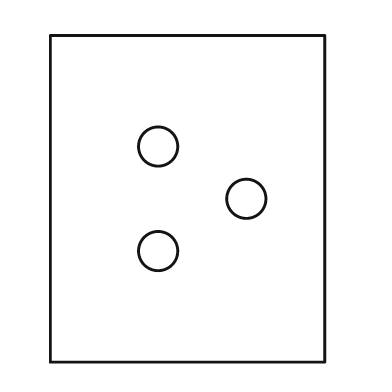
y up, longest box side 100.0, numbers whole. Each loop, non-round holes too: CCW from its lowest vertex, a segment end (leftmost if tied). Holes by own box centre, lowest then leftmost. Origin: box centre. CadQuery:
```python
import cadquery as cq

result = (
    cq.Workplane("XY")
    .moveTo(-42.0, -50.0)
    .lineTo(42.0, -50.0)
    .lineTo(42.0, 50.0)
    .lineTo(-42.0, 50.0)
    .close()
    .moveTo(-9.0, -16.0)
    .circle(6.0)
    .moveTo(18.0, 0.0)
    .circle(6.0)
    .moveTo(-9.0, 16.0)
    .circle(6.0)
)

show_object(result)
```